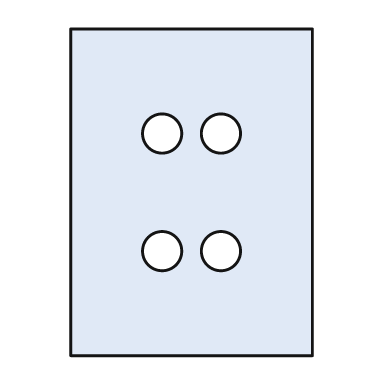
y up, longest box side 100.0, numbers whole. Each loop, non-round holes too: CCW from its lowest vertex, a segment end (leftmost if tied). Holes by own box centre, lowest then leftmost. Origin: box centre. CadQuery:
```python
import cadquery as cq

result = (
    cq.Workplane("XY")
    .moveTo(-37.0, -50.0)
    .lineTo(37.0, -50.0)
    .lineTo(37.0, 50.0)
    .lineTo(-37.0, 50.0)
    .close()
    .moveTo(-9.0, -18.0)
    .circle(6.0)
    .moveTo(9.0, -18.0)
    .circle(6.0)
    .moveTo(-9.0, 18.0)
    .circle(6.0)
    .moveTo(9.0, 18.0)
    .circle(6.0)
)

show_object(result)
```